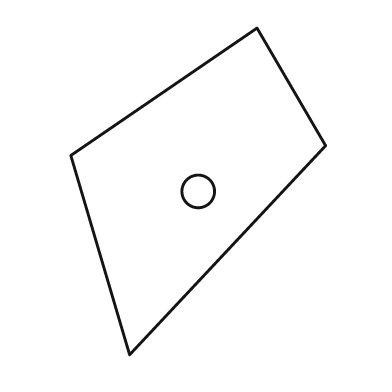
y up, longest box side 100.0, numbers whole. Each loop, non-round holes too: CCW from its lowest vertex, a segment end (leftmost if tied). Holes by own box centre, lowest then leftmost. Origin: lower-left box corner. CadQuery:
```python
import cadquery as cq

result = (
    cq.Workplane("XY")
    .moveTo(18.0, 0.0)
    .lineTo(78.0, 64.0)
    .lineTo(57.0, 100.0)
    .lineTo(0.0, 61.0)
    .close()
    .moveTo(39.0, 50.0)
    .circle(5.0)
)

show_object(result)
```